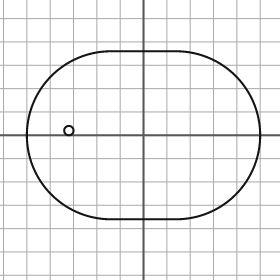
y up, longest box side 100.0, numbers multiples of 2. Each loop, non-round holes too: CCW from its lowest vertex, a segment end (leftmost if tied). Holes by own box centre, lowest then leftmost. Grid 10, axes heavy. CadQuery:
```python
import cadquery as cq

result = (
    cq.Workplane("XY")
    .moveTo(-14.0, -36.0)
    .lineTo(14.0, -36.0)
    .threePointArc((50.0, 0.0), (14.0, 36.0))
    .lineTo(-14.0, 36.0)
    .threePointArc((-50.0, 0.0), (-14.0, -36.0))
    .close()
    .moveTo(-32.0, 2.0)
    .circle(2.0)
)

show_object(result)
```